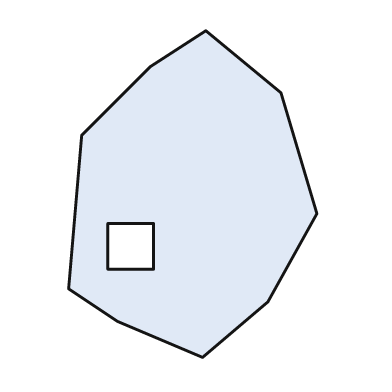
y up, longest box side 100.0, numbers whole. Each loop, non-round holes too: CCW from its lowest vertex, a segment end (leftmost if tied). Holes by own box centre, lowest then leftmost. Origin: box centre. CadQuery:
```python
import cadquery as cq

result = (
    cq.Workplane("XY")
    .moveTo(3.0, -50.0)
    .lineTo(23.0, -33.0)
    .lineTo(38.0, -6.0)
    .lineTo(27.0, 31.0)
    .lineTo(4.0, 50.0)
    .lineTo(-13.0, 39.0)
    .lineTo(-34.0, 18.0)
    .lineTo(-38.0, -29.0)
    .lineTo(-23.0, -39.0)
    .close()
    .moveTo(-26.0, -23.0)
    .lineTo(-12.0, -23.0)
    .lineTo(-12.0, -9.0)
    .lineTo(-26.0, -9.0)
    .close()
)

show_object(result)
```